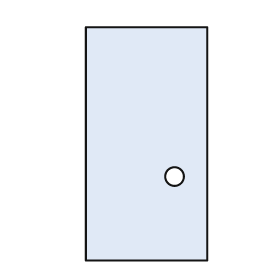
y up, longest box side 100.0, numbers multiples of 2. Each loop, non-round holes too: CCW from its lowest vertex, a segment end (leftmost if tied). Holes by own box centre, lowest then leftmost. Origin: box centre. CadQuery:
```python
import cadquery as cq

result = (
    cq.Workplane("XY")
    .moveTo(-26.0, -50.0)
    .lineTo(26.0, -50.0)
    .lineTo(26.0, 50.0)
    .lineTo(-26.0, 50.0)
    .close()
    .moveTo(12.0, -14.0)
    .circle(4.0)
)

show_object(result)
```